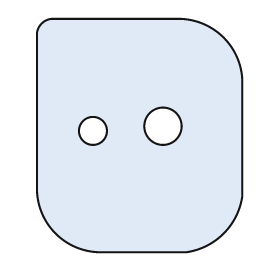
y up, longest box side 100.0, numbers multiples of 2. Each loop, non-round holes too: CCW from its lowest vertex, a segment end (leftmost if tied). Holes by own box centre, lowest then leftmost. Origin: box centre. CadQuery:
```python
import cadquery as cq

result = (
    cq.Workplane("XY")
    .moveTo(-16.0, -50.0)
    .lineTo(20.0, -50.0)
    .threePointArc((36.0, -42.0), (44.0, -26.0))
    .lineTo(44.0, 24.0)
    .threePointArc((36.0, 42.0), (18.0, 50.0))
    .lineTo(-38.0, 50.0)
    .threePointArc((-42.0, 48.0), (-44.0, 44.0))
    .lineTo(-44.0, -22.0)
    .threePointArc((-36.0, -42.0), (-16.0, -50.0))
    .close()
    .moveTo(-20.0, 2.0)
    .circle(6.0)
    .moveTo(10.0, 4.0)
    .circle(8.0)
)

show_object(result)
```